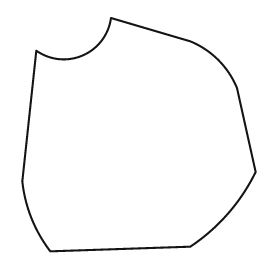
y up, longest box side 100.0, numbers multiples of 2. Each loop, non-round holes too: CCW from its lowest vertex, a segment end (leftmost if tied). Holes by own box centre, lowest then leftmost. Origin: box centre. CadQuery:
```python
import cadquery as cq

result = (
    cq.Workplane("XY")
    .moveTo(-38.0, -50.0)
    .lineTo(22.0, -48.0)
    .threePointArc((38.0, -34.0), (50.0, -16.0))
    .lineTo(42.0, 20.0)
    .threePointArc((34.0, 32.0), (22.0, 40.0))
    .lineTo(-12.0, 50.0)
    .threePointArc((-24.0, 34.0), (-44.0, 36.0))
    .lineTo(-50.0, -20.0)
    .threePointArc((-46.0, -36.0), (-38.0, -50.0))
    .close()
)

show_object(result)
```